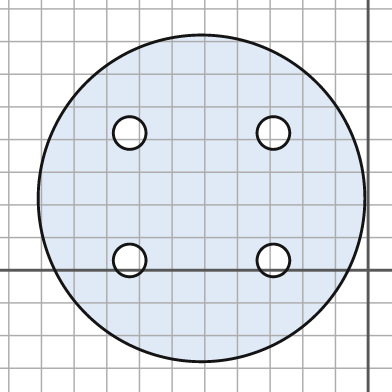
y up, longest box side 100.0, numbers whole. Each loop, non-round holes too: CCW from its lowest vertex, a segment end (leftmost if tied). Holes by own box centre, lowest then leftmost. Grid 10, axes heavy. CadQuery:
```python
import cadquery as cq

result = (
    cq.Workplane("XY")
    .moveTo(-51.0, 22.0)
    .circle(50.0)
    .moveTo(-73.0, 3.0)
    .circle(5.0)
    .moveTo(-29.0, 3.0)
    .circle(5.0)
    .moveTo(-73.0, 42.0)
    .circle(5.0)
    .moveTo(-29.0, 42.0)
    .circle(5.0)
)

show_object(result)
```